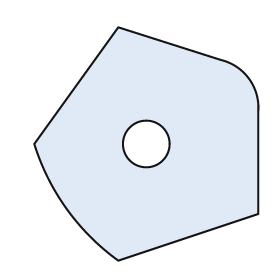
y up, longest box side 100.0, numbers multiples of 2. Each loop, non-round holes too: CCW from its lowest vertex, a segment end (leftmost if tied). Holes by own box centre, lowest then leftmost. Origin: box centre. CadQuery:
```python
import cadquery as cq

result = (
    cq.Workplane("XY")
    .moveTo(-12.0, -50.0)
    .lineTo(48.0, -30.0)
    .lineTo(48.0, 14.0)
    .threePointArc((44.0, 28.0), (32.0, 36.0))
    .lineTo(-12.0, 50.0)
    .lineTo(-48.0, 0.0)
    .threePointArc((-34.0, -28.0), (-12.0, -50.0))
    .close()
    .moveTo(0.0, 0.0)
    .circle(10.0)
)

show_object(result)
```